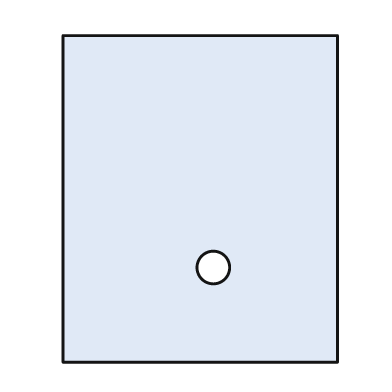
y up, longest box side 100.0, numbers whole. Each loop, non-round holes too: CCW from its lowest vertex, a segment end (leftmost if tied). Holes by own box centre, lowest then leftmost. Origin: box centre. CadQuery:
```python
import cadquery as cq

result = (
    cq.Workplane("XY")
    .moveTo(-42.0, -50.0)
    .lineTo(42.0, -50.0)
    .lineTo(42.0, 50.0)
    .lineTo(-42.0, 50.0)
    .close()
    .moveTo(4.0, -21.0)
    .circle(5.0)
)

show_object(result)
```